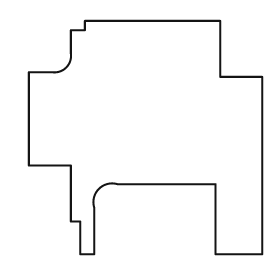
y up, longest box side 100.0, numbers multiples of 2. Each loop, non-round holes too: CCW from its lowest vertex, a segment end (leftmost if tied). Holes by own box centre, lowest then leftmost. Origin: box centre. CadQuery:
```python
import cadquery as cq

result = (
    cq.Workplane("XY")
    .moveTo(-28.0, -50.0)
    .lineTo(-22.0, -50.0)
    .lineTo(-22.0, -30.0)
    .threePointArc((-20.0, -22.0), (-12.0, -20.0))
    .lineTo(30.0, -20.0)
    .lineTo(30.0, -50.0)
    .lineTo(50.0, -50.0)
    .lineTo(50.0, 26.0)
    .lineTo(32.0, 26.0)
    .lineTo(32.0, 50.0)
    .lineTo(-26.0, 50.0)
    .lineTo(-26.0, 46.0)
    .lineTo(-32.0, 46.0)
    .lineTo(-32.0, 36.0)
    .threePointArc((-34.0, 30.0), (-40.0, 28.0))
    .lineTo(-50.0, 28.0)
    .lineTo(-50.0, -12.0)
    .lineTo(-32.0, -12.0)
    .lineTo(-32.0, -36.0)
    .lineTo(-28.0, -36.0)
    .close()
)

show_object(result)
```